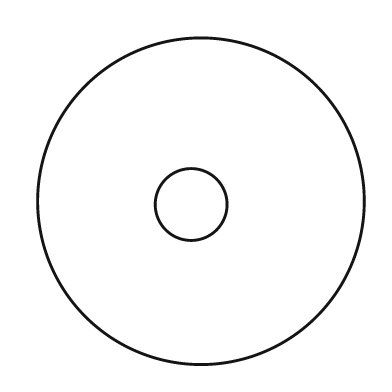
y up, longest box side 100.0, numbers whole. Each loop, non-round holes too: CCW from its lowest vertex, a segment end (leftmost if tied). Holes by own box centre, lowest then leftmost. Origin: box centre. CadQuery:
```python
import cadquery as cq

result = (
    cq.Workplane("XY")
    .moveTo(0.0, 0.0)
    .circle(50.0)
    .moveTo(-3.0, -1.0)
    .circle(11.0)
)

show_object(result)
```